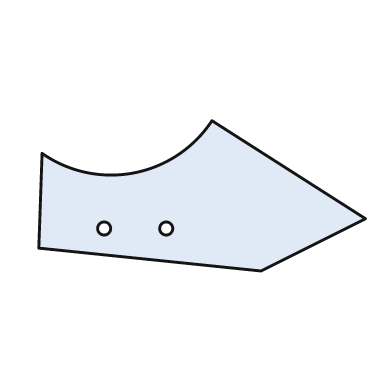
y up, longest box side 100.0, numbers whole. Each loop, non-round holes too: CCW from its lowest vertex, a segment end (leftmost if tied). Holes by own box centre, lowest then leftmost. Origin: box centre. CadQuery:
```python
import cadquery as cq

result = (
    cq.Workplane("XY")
    .moveTo(18.0, -23.0)
    .lineTo(50.0, -7.0)
    .lineTo(3.0, 23.0)
    .threePointArc((-21.0, 7.0), (-49.0, 13.0))
    .lineTo(-50.0, -16.0)
    .close()
    .moveTo(-30.0, -10.0)
    .circle(2.0)
    .moveTo(-11.0, -10.0)
    .circle(2.0)
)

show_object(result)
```